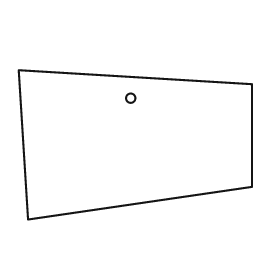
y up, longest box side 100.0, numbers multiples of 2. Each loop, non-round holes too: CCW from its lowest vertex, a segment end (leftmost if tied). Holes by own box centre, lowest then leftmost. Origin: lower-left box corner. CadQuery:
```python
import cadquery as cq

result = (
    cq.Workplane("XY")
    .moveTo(4.0, 0.0)
    .lineTo(100.0, 14.0)
    .lineTo(100.0, 58.0)
    .lineTo(0.0, 64.0)
    .close()
    .moveTo(48.0, 52.0)
    .circle(2.0)
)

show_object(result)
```